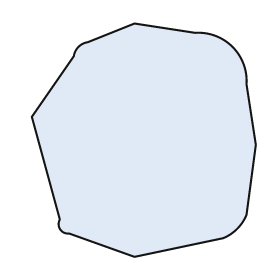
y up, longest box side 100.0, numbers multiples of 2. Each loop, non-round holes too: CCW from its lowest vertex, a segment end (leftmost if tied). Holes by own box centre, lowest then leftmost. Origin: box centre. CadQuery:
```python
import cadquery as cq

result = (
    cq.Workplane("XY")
    .moveTo(-4.0, -50.0)
    .lineTo(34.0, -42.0)
    .threePointArc((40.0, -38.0), (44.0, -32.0))
    .lineTo(48.0, -2.0)
    .lineTo(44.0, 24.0)
    .threePointArc((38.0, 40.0), (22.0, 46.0))
    .lineTo(-4.0, 50.0)
    .lineTo(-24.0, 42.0)
    .threePointArc((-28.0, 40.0), (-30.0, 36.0))
    .lineTo(-48.0, 10.0)
    .lineTo(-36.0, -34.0)
    .threePointArc((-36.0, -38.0), (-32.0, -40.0))
    .close()
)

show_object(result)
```